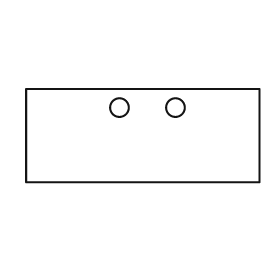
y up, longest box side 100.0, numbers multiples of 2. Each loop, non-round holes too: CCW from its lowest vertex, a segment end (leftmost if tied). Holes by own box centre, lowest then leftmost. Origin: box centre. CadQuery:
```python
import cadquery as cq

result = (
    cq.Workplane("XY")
    .moveTo(-50.0, -20.0)
    .lineTo(50.0, -20.0)
    .lineTo(50.0, 20.0)
    .lineTo(-50.0, 20.0)
    .close()
    .moveTo(-10.0, 12.0)
    .circle(4.0)
    .moveTo(14.0, 12.0)
    .circle(4.0)
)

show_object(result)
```